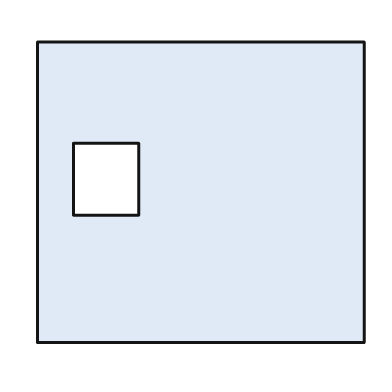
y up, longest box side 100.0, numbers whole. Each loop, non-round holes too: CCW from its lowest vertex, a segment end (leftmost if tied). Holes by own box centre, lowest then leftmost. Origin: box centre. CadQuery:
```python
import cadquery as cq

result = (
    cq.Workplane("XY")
    .moveTo(-50.0, -46.0)
    .lineTo(50.0, -46.0)
    .lineTo(50.0, 46.0)
    .lineTo(-50.0, 46.0)
    .close()
    .moveTo(-39.0, -7.0)
    .lineTo(-19.0, -7.0)
    .lineTo(-19.0, 15.0)
    .lineTo(-39.0, 15.0)
    .close()
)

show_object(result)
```